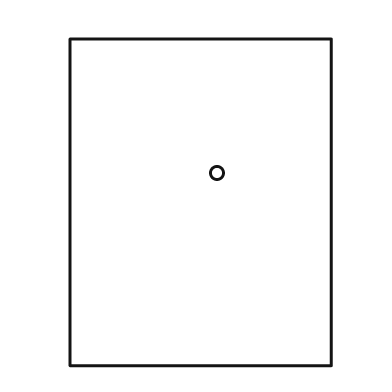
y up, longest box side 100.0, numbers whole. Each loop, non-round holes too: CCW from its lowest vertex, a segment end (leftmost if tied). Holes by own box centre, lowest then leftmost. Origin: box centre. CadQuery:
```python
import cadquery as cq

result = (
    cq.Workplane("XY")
    .moveTo(-40.0, -50.0)
    .lineTo(40.0, -50.0)
    .lineTo(40.0, 50.0)
    .lineTo(-40.0, 50.0)
    .close()
    .moveTo(5.0, 9.0)
    .circle(2.0)
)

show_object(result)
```